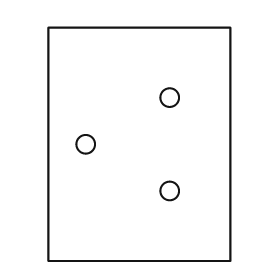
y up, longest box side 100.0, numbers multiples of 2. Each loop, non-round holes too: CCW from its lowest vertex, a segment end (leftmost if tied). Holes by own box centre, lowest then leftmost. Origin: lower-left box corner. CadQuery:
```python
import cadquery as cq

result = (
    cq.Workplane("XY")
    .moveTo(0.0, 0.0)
    .lineTo(78.0, 0.0)
    .lineTo(78.0, 100.0)
    .lineTo(0.0, 100.0)
    .close()
    .moveTo(52.0, 30.0)
    .circle(4.0)
    .moveTo(16.0, 50.0)
    .circle(4.0)
    .moveTo(52.0, 70.0)
    .circle(4.0)
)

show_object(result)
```